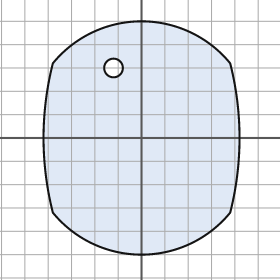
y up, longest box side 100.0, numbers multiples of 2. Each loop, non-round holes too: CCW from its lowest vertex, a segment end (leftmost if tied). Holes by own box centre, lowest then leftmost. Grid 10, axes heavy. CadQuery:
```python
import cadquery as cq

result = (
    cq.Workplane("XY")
    .moveTo(-38.0, -32.0)
    .threePointArc((0.0, -50.0), (38.0, -32.0))
    .threePointArc((42.0, 0.0), (38.0, 32.0))
    .threePointArc((0.0, 50.0), (-38.0, 32.0))
    .threePointArc((-42.0, 0.0), (-38.0, -32.0))
    .close()
    .moveTo(-12.0, 30.0)
    .circle(4.0)
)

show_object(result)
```